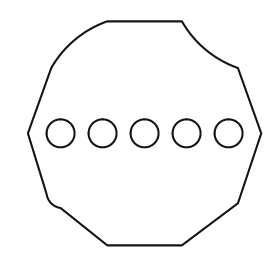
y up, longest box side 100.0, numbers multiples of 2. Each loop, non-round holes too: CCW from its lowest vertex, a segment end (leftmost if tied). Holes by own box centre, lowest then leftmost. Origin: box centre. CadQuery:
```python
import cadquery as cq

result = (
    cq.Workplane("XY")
    .moveTo(-16.0, -48.0)
    .lineTo(16.0, -48.0)
    .lineTo(40.0, -30.0)
    .lineTo(50.0, 0.0)
    .lineTo(40.0, 28.0)
    .threePointArc((26.0, 36.0), (16.0, 48.0))
    .lineTo(-16.0, 48.0)
    .threePointArc((-30.0, 40.0), (-40.0, 28.0))
    .lineTo(-50.0, 0.0)
    .lineTo(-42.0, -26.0)
    .threePointArc((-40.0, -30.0), (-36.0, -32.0))
    .close()
    .moveTo(-36.0, 0.0)
    .circle(6.0)
    .moveTo(-18.0, 0.0)
    .circle(6.0)
    .moveTo(0.0, 0.0)
    .circle(6.0)
    .moveTo(18.0, 0.0)
    .circle(6.0)
    .moveTo(36.0, 0.0)
    .circle(6.0)
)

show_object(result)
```